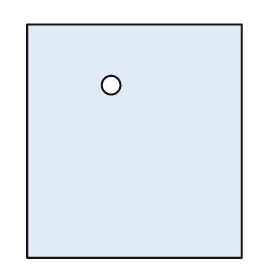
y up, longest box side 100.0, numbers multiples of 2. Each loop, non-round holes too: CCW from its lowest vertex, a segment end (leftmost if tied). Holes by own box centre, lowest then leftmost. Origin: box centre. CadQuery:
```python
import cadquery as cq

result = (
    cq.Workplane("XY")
    .moveTo(-46.0, -50.0)
    .lineTo(46.0, -50.0)
    .lineTo(46.0, 50.0)
    .lineTo(-46.0, 50.0)
    .close()
    .moveTo(-10.0, 24.0)
    .circle(4.0)
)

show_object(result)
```